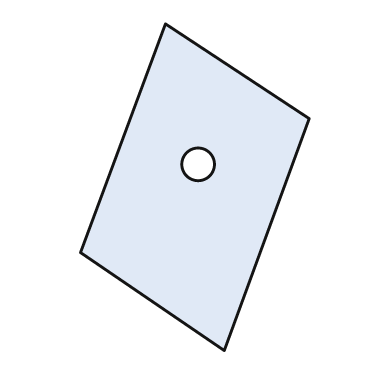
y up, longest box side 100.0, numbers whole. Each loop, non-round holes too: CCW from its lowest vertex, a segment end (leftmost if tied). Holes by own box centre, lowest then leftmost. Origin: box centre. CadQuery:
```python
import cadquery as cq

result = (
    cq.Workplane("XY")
    .moveTo(9.0, -50.0)
    .lineTo(35.0, 21.0)
    .lineTo(-9.0, 50.0)
    .lineTo(-35.0, -20.0)
    .close()
    .moveTo(1.0, 7.0)
    .circle(5.0)
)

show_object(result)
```